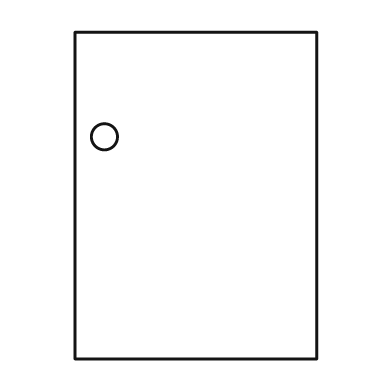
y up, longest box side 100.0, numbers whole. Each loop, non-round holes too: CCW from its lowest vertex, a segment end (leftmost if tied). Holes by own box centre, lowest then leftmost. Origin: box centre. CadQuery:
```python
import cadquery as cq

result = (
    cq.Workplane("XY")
    .moveTo(-37.0, -50.0)
    .lineTo(37.0, -50.0)
    .lineTo(37.0, 50.0)
    .lineTo(-37.0, 50.0)
    .close()
    .moveTo(-28.0, 18.0)
    .circle(4.0)
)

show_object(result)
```